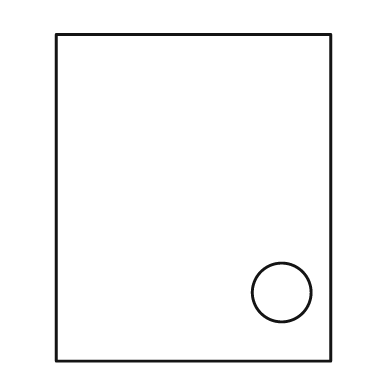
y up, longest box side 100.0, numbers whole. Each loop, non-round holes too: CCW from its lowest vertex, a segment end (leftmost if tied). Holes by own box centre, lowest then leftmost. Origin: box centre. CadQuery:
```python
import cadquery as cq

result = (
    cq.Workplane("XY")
    .moveTo(-42.0, -50.0)
    .lineTo(42.0, -50.0)
    .lineTo(42.0, 50.0)
    .lineTo(-42.0, 50.0)
    .close()
    .moveTo(27.0, -29.0)
    .circle(9.0)
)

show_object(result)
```